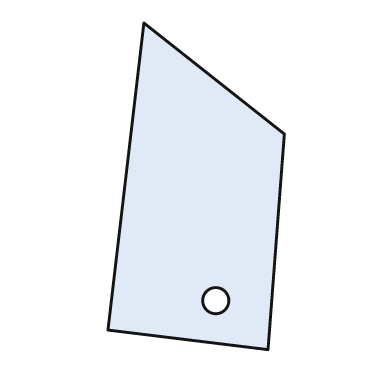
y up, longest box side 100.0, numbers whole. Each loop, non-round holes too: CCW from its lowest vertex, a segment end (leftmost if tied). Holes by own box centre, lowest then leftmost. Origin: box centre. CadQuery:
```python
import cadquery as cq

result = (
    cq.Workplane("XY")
    .moveTo(22.0, -50.0)
    .lineTo(27.0, 16.0)
    .lineTo(-16.0, 50.0)
    .lineTo(-27.0, -44.0)
    .close()
    .moveTo(6.0, -35.0)
    .circle(4.0)
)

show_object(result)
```